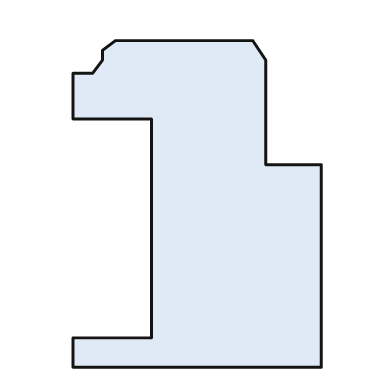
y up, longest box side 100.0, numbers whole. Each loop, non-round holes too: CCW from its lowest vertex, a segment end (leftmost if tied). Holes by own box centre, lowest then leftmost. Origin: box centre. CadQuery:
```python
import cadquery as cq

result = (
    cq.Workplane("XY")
    .moveTo(-38.0, -50.0)
    .lineTo(38.0, -50.0)
    .lineTo(38.0, 12.0)
    .lineTo(21.0, 12.0)
    .lineTo(21.0, 44.0)
    .lineTo(17.0, 50.0)
    .lineTo(-25.0, 50.0)
    .lineTo(-29.0, 47.0)
    .lineTo(-29.0, 44.0)
    .lineTo(-32.0, 40.0)
    .lineTo(-38.0, 40.0)
    .lineTo(-38.0, 26.0)
    .lineTo(-14.0, 26.0)
    .lineTo(-14.0, -41.0)
    .lineTo(-38.0, -41.0)
    .close()
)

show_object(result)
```